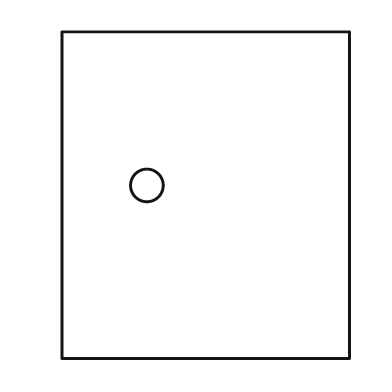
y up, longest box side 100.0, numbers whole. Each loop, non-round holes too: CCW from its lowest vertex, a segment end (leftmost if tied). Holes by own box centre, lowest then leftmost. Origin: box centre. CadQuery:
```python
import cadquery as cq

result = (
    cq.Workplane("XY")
    .moveTo(-44.0, -50.0)
    .lineTo(44.0, -50.0)
    .lineTo(44.0, 50.0)
    .lineTo(-44.0, 50.0)
    .close()
    .moveTo(-18.0, 3.0)
    .circle(5.0)
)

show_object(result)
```